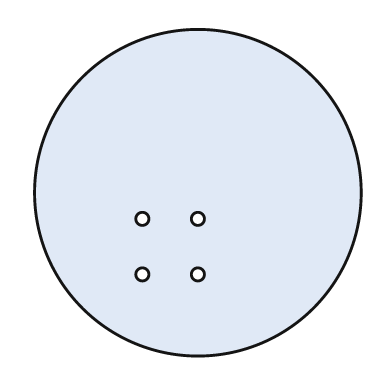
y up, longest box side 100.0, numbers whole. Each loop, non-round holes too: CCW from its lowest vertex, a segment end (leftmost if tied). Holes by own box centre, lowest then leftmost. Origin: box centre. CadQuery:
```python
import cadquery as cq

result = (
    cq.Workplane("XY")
    .moveTo(0.0, 0.0)
    .circle(50.0)
    .moveTo(-17.0, -25.0)
    .circle(2.0)
    .moveTo(0.0, -25.0)
    .circle(2.0)
    .moveTo(-17.0, -8.0)
    .circle(2.0)
    .moveTo(0.0, -8.0)
    .circle(2.0)
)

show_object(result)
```